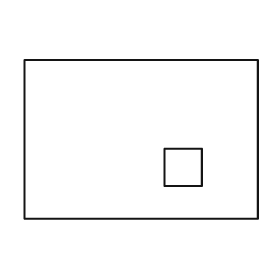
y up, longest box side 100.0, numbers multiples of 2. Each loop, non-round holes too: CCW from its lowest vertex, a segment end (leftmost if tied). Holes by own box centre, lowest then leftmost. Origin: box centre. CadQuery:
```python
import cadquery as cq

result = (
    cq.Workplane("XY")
    .moveTo(-50.0, -34.0)
    .lineTo(50.0, -34.0)
    .lineTo(50.0, 34.0)
    .lineTo(-50.0, 34.0)
    .close()
    .moveTo(10.0, -20.0)
    .lineTo(26.0, -20.0)
    .lineTo(26.0, -4.0)
    .lineTo(10.0, -4.0)
    .close()
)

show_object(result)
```